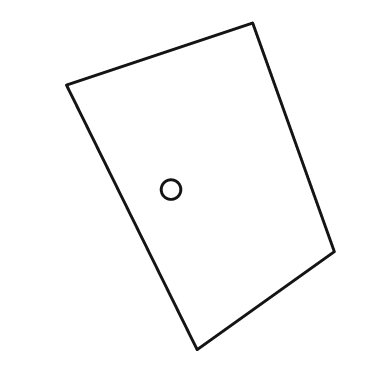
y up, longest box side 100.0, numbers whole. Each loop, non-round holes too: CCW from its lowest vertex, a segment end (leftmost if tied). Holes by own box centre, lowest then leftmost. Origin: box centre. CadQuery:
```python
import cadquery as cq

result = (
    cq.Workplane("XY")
    .moveTo(-1.0, -50.0)
    .lineTo(41.0, -20.0)
    .lineTo(16.0, 50.0)
    .lineTo(-41.0, 31.0)
    .close()
    .moveTo(-9.0, -1.0)
    .circle(3.0)
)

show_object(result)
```